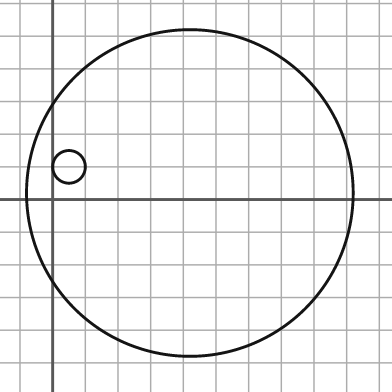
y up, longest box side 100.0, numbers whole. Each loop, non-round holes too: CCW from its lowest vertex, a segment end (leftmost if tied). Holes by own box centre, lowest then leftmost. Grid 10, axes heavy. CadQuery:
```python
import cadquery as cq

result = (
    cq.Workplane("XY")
    .moveTo(42.0, 2.0)
    .circle(50.0)
    .moveTo(5.0, 10.0)
    .circle(5.0)
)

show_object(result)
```